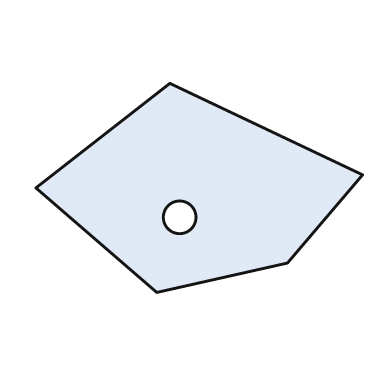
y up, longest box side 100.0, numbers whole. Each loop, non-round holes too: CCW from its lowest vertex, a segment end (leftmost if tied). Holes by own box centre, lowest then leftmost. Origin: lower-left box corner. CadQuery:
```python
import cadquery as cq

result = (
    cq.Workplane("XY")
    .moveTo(37.0, 0.0)
    .lineTo(77.0, 9.0)
    .lineTo(100.0, 36.0)
    .lineTo(41.0, 64.0)
    .lineTo(0.0, 32.0)
    .close()
    .moveTo(44.0, 23.0)
    .circle(5.0)
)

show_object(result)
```